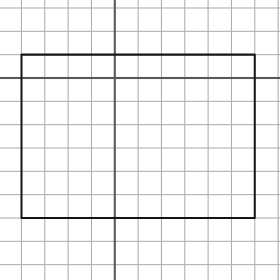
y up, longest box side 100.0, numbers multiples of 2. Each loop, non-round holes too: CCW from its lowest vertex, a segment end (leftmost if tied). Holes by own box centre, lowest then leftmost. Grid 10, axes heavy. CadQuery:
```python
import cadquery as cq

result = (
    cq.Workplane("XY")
    .moveTo(-40.0, -60.0)
    .lineTo(60.0, -60.0)
    .lineTo(60.0, 10.0)
    .lineTo(-40.0, 10.0)
    .close()
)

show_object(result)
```